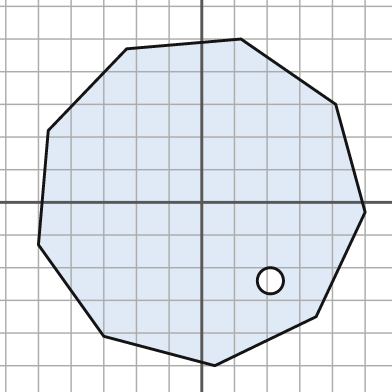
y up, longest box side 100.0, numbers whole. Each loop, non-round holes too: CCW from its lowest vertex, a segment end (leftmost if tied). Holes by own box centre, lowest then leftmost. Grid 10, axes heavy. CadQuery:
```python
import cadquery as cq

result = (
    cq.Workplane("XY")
    .moveTo(4.0, -50.0)
    .lineTo(35.0, -35.0)
    .lineTo(50.0, -3.0)
    .lineTo(41.0, 30.0)
    .lineTo(12.0, 50.0)
    .lineTo(-23.0, 47.0)
    .lineTo(-47.0, 22.0)
    .lineTo(-50.0, -13.0)
    .lineTo(-30.0, -41.0)
    .close()
    .moveTo(21.0, -24.0)
    .circle(4.0)
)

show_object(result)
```